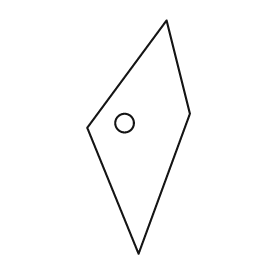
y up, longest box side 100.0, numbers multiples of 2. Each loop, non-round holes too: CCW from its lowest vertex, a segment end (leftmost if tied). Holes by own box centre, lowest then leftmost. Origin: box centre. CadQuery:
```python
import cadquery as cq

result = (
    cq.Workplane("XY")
    .moveTo(0.0, -50.0)
    .lineTo(22.0, 10.0)
    .lineTo(12.0, 50.0)
    .lineTo(-22.0, 4.0)
    .close()
    .moveTo(-6.0, 6.0)
    .circle(4.0)
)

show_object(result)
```